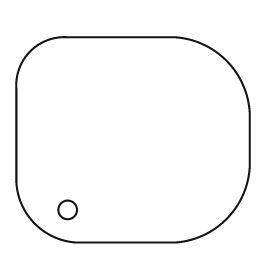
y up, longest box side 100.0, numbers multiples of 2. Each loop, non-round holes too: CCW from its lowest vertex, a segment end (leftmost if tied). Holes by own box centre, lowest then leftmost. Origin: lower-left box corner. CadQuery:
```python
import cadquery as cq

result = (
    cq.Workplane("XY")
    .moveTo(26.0, 0.0)
    .lineTo(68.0, 0.0)
    .threePointArc((90.0, 10.0), (100.0, 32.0))
    .lineTo(100.0, 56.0)
    .threePointArc((90.0, 78.0), (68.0, 88.0))
    .lineTo(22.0, 88.0)
    .threePointArc((6.0, 82.0), (0.0, 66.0))
    .lineTo(0.0, 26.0)
    .threePointArc((8.0, 8.0), (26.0, 0.0))
    .close()
    .moveTo(22.0, 14.0)
    .circle(4.0)
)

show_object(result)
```